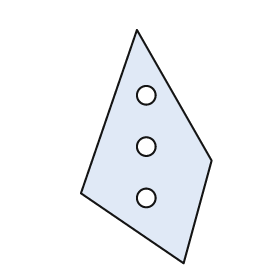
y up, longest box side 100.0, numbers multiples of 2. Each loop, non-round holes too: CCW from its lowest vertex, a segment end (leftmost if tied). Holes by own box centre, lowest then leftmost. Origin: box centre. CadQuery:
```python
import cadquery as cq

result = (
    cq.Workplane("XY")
    .moveTo(16.0, -50.0)
    .lineTo(28.0, -6.0)
    .lineTo(-4.0, 50.0)
    .lineTo(-28.0, -20.0)
    .close()
    .moveTo(0.0, -22.0)
    .circle(4.0)
    .moveTo(0.0, 0.0)
    .circle(4.0)
    .moveTo(0.0, 22.0)
    .circle(4.0)
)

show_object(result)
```